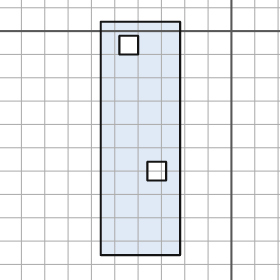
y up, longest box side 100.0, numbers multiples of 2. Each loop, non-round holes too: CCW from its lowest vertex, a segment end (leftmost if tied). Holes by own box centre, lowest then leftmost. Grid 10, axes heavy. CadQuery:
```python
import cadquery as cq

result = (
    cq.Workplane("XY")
    .moveTo(-56.0, -96.0)
    .lineTo(-22.0, -96.0)
    .lineTo(-22.0, 4.0)
    .lineTo(-56.0, 4.0)
    .close()
    .moveTo(-36.0, -64.0)
    .lineTo(-28.0, -64.0)
    .lineTo(-28.0, -56.0)
    .lineTo(-36.0, -56.0)
    .close()
    .moveTo(-48.0, -10.0)
    .lineTo(-40.0, -10.0)
    .lineTo(-40.0, -2.0)
    .lineTo(-48.0, -2.0)
    .close()
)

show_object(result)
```